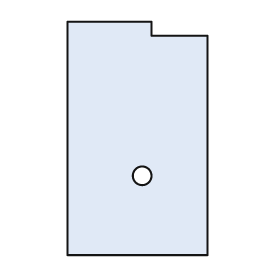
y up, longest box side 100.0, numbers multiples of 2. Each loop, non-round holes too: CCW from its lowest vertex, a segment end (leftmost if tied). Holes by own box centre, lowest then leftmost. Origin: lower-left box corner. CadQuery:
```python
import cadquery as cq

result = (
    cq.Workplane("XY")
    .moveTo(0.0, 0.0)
    .lineTo(60.0, 0.0)
    .lineTo(60.0, 94.0)
    .lineTo(36.0, 94.0)
    .lineTo(36.0, 100.0)
    .lineTo(0.0, 100.0)
    .close()
    .moveTo(32.0, 34.0)
    .circle(4.0)
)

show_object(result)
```